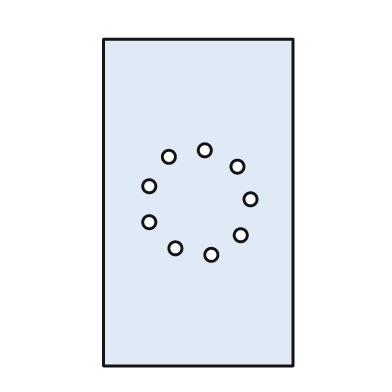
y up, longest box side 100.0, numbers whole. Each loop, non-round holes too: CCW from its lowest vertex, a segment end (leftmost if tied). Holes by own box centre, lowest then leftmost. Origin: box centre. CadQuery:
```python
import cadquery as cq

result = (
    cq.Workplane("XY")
    .moveTo(-29.0, -50.0)
    .lineTo(29.0, -50.0)
    .lineTo(29.0, 50.0)
    .lineTo(-29.0, 50.0)
    .close()
    .moveTo(4.0, -16.0)
    .circle(2.0)
    .moveTo(-7.0, -14.0)
    .circle(2.0)
    .moveTo(13.0, -10.0)
    .circle(2.0)
    .moveTo(-15.0, -6.0)
    .circle(2.0)
    .moveTo(16.0, 1.0)
    .circle(2.0)
    .moveTo(-15.0, 5.0)
    .circle(2.0)
    .moveTo(12.0, 11.0)
    .circle(2.0)
    .moveTo(-9.0, 14.0)
    .circle(2.0)
    .moveTo(2.0, 16.0)
    .circle(2.0)
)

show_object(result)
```